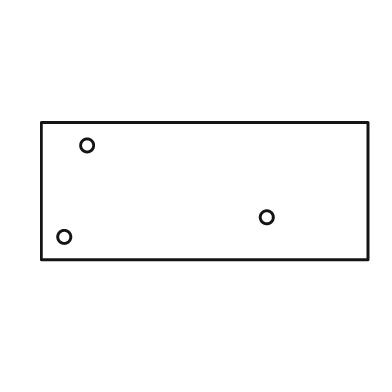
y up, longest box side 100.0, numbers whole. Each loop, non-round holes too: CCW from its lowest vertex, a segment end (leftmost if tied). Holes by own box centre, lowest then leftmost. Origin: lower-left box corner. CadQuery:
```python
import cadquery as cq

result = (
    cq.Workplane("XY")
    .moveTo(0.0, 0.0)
    .lineTo(100.0, 0.0)
    .lineTo(100.0, 42.0)
    .lineTo(0.0, 42.0)
    .close()
    .moveTo(7.0, 7.0)
    .circle(2.0)
    .moveTo(69.0, 13.0)
    .circle(2.0)
    .moveTo(14.0, 35.0)
    .circle(2.0)
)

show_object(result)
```